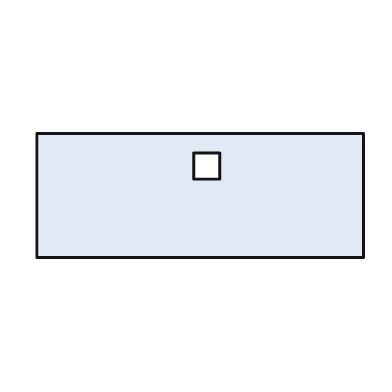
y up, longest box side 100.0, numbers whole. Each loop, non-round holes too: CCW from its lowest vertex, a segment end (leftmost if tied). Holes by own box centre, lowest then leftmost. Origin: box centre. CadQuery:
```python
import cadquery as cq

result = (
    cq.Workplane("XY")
    .moveTo(-50.0, -19.0)
    .lineTo(50.0, -19.0)
    .lineTo(50.0, 19.0)
    .lineTo(-50.0, 19.0)
    .close()
    .moveTo(-2.0, 5.0)
    .lineTo(6.0, 5.0)
    .lineTo(6.0, 13.0)
    .lineTo(-2.0, 13.0)
    .close()
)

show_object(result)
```